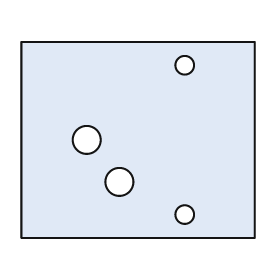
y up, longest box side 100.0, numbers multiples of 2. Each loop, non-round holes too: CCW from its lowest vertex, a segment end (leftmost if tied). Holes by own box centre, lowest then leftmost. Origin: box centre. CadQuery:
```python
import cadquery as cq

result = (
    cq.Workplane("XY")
    .moveTo(-50.0, -42.0)
    .lineTo(50.0, -42.0)
    .lineTo(50.0, 42.0)
    .lineTo(-50.0, 42.0)
    .close()
    .moveTo(20.0, -32.0)
    .circle(4.0)
    .moveTo(-8.0, -18.0)
    .circle(6.0)
    .moveTo(-22.0, 0.0)
    .circle(6.0)
    .moveTo(20.0, 32.0)
    .circle(4.0)
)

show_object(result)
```